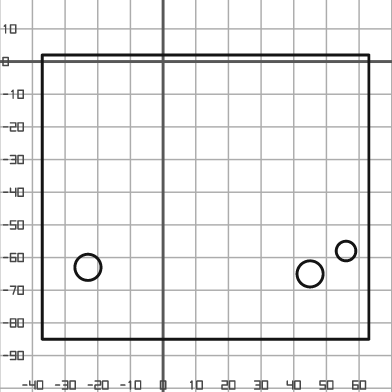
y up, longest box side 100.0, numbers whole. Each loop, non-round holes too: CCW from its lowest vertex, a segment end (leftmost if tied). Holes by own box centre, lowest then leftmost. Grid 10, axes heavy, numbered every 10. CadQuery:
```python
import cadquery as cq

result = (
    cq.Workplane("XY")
    .moveTo(-37.0, -85.0)
    .lineTo(63.0, -85.0)
    .lineTo(63.0, 2.0)
    .lineTo(-37.0, 2.0)
    .close()
    .moveTo(45.0, -65.0)
    .circle(4.0)
    .moveTo(-23.0, -63.0)
    .circle(4.0)
    .moveTo(56.0, -58.0)
    .circle(3.0)
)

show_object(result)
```